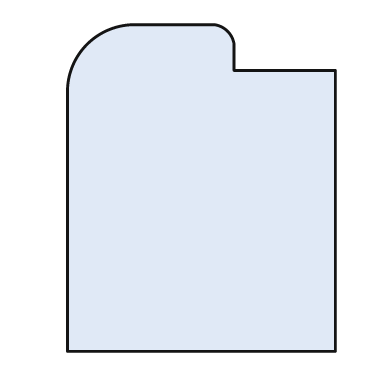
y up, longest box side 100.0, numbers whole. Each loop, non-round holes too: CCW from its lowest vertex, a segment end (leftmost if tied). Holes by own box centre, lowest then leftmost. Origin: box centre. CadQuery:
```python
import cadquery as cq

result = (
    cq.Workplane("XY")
    .moveTo(-41.0, -50.0)
    .lineTo(41.0, -50.0)
    .lineTo(41.0, 36.0)
    .lineTo(10.0, 36.0)
    .lineTo(10.0, 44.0)
    .threePointArc((8.0, 48.0), (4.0, 50.0))
    .lineTo(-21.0, 50.0)
    .threePointArc((-35.0, 44.0), (-41.0, 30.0))
    .close()
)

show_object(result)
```